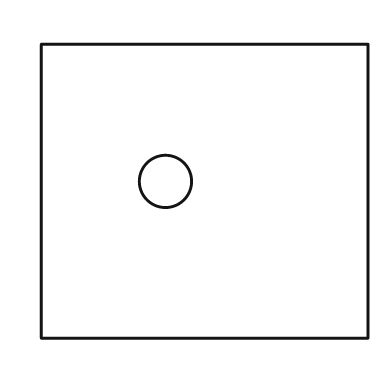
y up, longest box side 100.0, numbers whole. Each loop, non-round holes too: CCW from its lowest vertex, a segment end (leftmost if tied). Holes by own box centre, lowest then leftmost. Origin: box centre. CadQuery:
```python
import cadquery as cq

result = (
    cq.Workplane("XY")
    .moveTo(-50.0, -45.0)
    .lineTo(50.0, -45.0)
    .lineTo(50.0, 45.0)
    .lineTo(-50.0, 45.0)
    .close()
    .moveTo(-12.0, 3.0)
    .circle(8.0)
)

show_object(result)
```